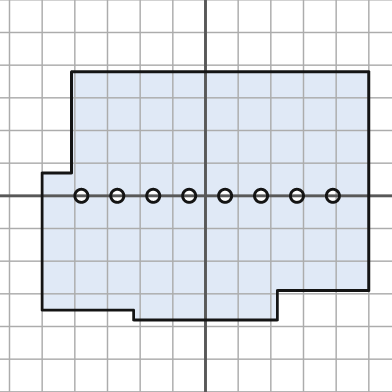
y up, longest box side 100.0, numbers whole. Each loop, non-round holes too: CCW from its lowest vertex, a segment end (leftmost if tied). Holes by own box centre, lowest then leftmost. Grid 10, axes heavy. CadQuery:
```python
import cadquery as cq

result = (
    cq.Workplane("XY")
    .moveTo(-22.0, -38.0)
    .lineTo(22.0, -38.0)
    .lineTo(22.0, -29.0)
    .lineTo(50.0, -29.0)
    .lineTo(50.0, 38.0)
    .lineTo(-41.0, 38.0)
    .lineTo(-41.0, 7.0)
    .lineTo(-50.0, 7.0)
    .lineTo(-50.0, -35.0)
    .lineTo(-22.0, -35.0)
    .close()
    .moveTo(-38.0, 0.0)
    .circle(2.0)
    .moveTo(-27.0, 0.0)
    .circle(2.0)
    .moveTo(-16.0, 0.0)
    .circle(2.0)
    .moveTo(-5.0, 0.0)
    .circle(2.0)
    .moveTo(6.0, 0.0)
    .circle(2.0)
    .moveTo(17.0, 0.0)
    .circle(2.0)
    .moveTo(28.0, 0.0)
    .circle(2.0)
    .moveTo(39.0, 0.0)
    .circle(2.0)
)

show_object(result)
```